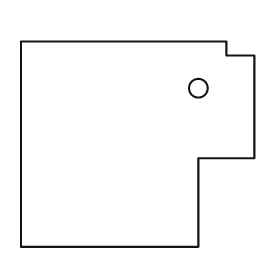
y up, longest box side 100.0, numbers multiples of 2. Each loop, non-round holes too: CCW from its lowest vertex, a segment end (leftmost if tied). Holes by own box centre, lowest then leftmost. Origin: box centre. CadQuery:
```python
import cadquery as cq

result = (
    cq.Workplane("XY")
    .moveTo(-50.0, -44.0)
    .lineTo(26.0, -44.0)
    .lineTo(26.0, -6.0)
    .lineTo(50.0, -6.0)
    .lineTo(50.0, 38.0)
    .lineTo(38.0, 38.0)
    .lineTo(38.0, 44.0)
    .lineTo(-50.0, 44.0)
    .close()
    .moveTo(26.0, 24.0)
    .circle(4.0)
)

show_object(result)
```